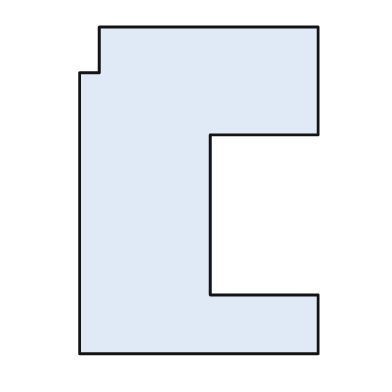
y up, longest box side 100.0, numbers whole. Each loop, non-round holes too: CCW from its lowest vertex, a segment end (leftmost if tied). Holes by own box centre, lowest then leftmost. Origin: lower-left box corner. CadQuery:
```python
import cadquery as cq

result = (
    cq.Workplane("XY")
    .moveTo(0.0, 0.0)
    .lineTo(73.0, 0.0)
    .lineTo(73.0, 18.0)
    .lineTo(40.0, 18.0)
    .lineTo(40.0, 67.0)
    .lineTo(73.0, 67.0)
    .lineTo(73.0, 100.0)
    .lineTo(6.0, 100.0)
    .lineTo(6.0, 86.0)
    .lineTo(0.0, 86.0)
    .close()
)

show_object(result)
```